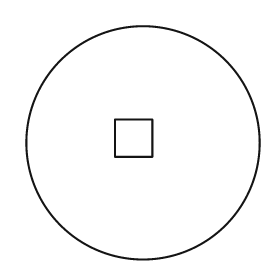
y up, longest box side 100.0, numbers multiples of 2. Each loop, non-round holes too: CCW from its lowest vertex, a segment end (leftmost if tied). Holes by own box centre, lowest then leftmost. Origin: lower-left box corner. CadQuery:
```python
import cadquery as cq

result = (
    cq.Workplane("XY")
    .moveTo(50.0, 50.0)
    .circle(50.0)
    .moveTo(38.0, 44.0)
    .lineTo(54.0, 44.0)
    .lineTo(54.0, 60.0)
    .lineTo(38.0, 60.0)
    .close()
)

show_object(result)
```